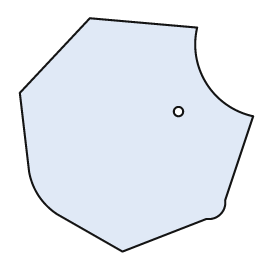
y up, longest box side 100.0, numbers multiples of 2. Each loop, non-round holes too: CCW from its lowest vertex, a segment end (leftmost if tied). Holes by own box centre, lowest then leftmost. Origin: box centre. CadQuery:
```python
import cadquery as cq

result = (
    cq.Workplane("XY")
    .moveTo(-6.0, -50.0)
    .lineTo(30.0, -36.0)
    .threePointArc((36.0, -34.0), (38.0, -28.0))
    .lineTo(50.0, 8.0)
    .threePointArc((30.0, 22.0), (26.0, 46.0))
    .lineTo(-20.0, 50.0)
    .lineTo(-50.0, 18.0)
    .lineTo(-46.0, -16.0)
    .threePointArc((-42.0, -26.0), (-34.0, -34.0))
    .close()
    .moveTo(18.0, 10.0)
    .circle(2.0)
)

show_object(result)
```